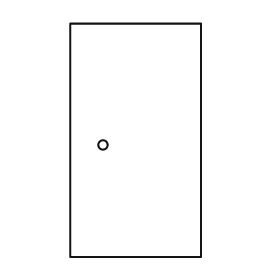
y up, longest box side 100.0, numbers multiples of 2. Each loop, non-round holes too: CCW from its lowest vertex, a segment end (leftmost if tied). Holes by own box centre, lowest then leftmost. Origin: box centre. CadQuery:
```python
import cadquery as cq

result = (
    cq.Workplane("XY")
    .moveTo(-28.0, -50.0)
    .lineTo(28.0, -50.0)
    .lineTo(28.0, 50.0)
    .lineTo(-28.0, 50.0)
    .close()
    .moveTo(-14.0, -2.0)
    .circle(2.0)
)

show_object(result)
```